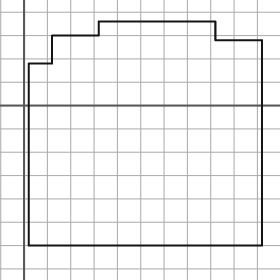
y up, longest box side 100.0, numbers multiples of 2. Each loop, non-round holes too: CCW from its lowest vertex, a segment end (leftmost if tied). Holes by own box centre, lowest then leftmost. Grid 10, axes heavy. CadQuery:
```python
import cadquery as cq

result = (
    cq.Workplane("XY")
    .moveTo(2.0, -60.0)
    .lineTo(102.0, -60.0)
    .lineTo(102.0, 28.0)
    .lineTo(82.0, 28.0)
    .lineTo(82.0, 36.0)
    .lineTo(32.0, 36.0)
    .lineTo(32.0, 30.0)
    .lineTo(12.0, 30.0)
    .lineTo(12.0, 18.0)
    .lineTo(2.0, 18.0)
    .close()
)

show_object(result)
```